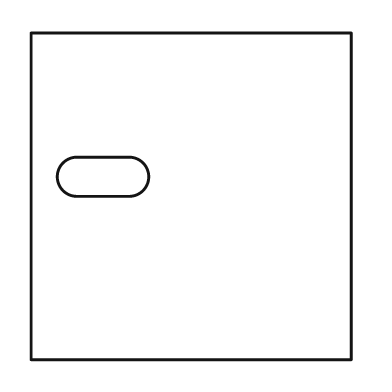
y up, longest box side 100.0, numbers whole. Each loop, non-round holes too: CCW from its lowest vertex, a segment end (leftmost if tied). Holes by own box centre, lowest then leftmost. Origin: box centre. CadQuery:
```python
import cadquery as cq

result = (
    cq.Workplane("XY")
    .moveTo(-49.0, -50.0)
    .lineTo(49.0, -50.0)
    .lineTo(49.0, 50.0)
    .lineTo(-49.0, 50.0)
    .close()
    .moveTo(-35.0, 0.0)
    .lineTo(-19.0, 0.0)
    .threePointArc((-13.0, 6.0), (-19.0, 12.0))
    .lineTo(-35.0, 12.0)
    .threePointArc((-41.0, 6.0), (-35.0, 0.0))
    .close()
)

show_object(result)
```